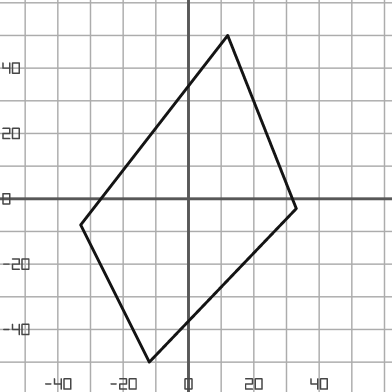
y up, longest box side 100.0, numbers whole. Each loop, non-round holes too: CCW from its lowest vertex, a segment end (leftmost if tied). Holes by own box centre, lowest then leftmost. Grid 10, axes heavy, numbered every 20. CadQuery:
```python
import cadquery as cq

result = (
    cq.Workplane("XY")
    .moveTo(-12.0, -50.0)
    .lineTo(33.0, -3.0)
    .lineTo(12.0, 50.0)
    .lineTo(-33.0, -8.0)
    .close()
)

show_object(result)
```